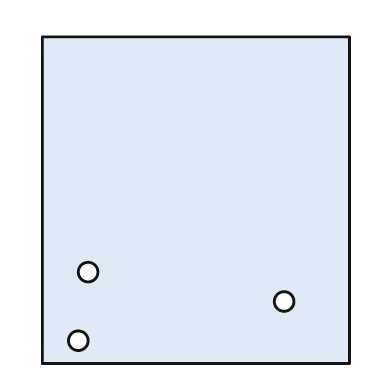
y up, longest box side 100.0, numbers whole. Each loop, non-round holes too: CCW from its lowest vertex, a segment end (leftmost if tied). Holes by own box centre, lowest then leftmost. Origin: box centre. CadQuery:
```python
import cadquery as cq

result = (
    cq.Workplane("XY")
    .moveTo(-47.0, -50.0)
    .lineTo(47.0, -50.0)
    .lineTo(47.0, 50.0)
    .lineTo(-47.0, 50.0)
    .close()
    .moveTo(-36.0, -43.0)
    .circle(3.0)
    .moveTo(27.0, -31.0)
    .circle(3.0)
    .moveTo(-33.0, -22.0)
    .circle(3.0)
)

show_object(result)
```